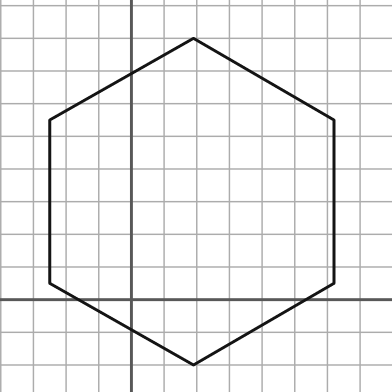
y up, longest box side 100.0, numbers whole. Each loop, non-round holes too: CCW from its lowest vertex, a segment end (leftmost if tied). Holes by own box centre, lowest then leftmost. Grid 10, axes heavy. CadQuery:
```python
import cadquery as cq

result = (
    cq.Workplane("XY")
    .moveTo(19.0, -20.0)
    .lineTo(62.0, 5.0)
    .lineTo(62.0, 55.0)
    .lineTo(19.0, 80.0)
    .lineTo(-25.0, 55.0)
    .lineTo(-25.0, 5.0)
    .close()
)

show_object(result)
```